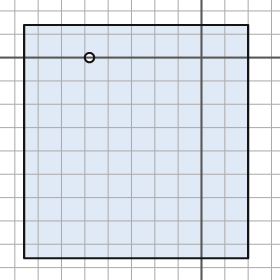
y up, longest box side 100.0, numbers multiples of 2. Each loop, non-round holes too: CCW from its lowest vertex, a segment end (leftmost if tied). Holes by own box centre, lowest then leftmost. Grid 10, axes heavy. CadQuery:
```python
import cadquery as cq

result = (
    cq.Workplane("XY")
    .moveTo(-76.0, -86.0)
    .lineTo(20.0, -86.0)
    .lineTo(20.0, 14.0)
    .lineTo(-76.0, 14.0)
    .close()
    .moveTo(-48.0, 0.0)
    .circle(2.0)
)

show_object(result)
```